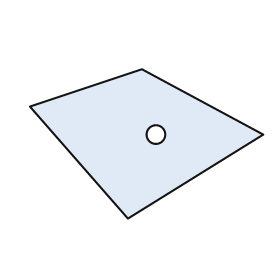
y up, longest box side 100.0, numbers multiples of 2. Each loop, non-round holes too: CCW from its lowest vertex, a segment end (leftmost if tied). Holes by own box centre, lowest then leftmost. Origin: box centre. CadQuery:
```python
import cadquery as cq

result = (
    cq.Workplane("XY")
    .moveTo(-8.0, -32.0)
    .lineTo(50.0, 4.0)
    .lineTo(-2.0, 32.0)
    .lineTo(-50.0, 16.0)
    .close()
    .moveTo(4.0, 4.0)
    .circle(4.0)
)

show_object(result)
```